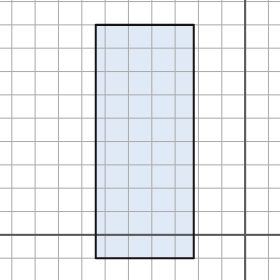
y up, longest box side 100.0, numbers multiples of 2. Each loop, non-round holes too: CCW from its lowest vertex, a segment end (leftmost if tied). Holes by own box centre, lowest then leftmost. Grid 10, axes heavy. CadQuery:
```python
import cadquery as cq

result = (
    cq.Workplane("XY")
    .moveTo(-64.0, -10.0)
    .lineTo(-22.0, -10.0)
    .lineTo(-22.0, 90.0)
    .lineTo(-64.0, 90.0)
    .close()
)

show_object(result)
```